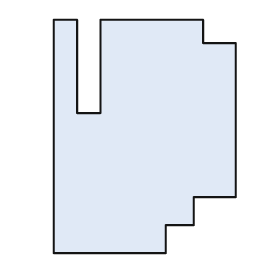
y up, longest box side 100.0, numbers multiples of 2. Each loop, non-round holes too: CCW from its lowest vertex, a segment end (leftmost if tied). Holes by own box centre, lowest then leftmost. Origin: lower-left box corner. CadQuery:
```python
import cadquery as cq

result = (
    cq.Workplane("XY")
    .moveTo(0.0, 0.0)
    .lineTo(48.0, 0.0)
    .lineTo(48.0, 12.0)
    .lineTo(60.0, 12.0)
    .lineTo(60.0, 24.0)
    .lineTo(78.0, 24.0)
    .lineTo(78.0, 90.0)
    .lineTo(64.0, 90.0)
    .lineTo(64.0, 100.0)
    .lineTo(20.0, 100.0)
    .lineTo(20.0, 60.0)
    .lineTo(10.0, 60.0)
    .lineTo(10.0, 100.0)
    .lineTo(0.0, 100.0)
    .close()
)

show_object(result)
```